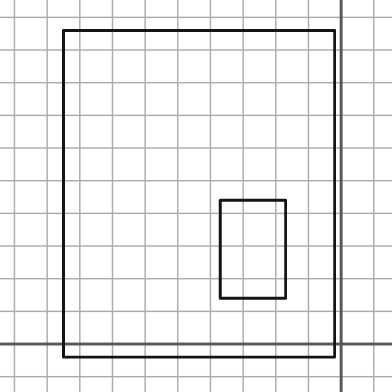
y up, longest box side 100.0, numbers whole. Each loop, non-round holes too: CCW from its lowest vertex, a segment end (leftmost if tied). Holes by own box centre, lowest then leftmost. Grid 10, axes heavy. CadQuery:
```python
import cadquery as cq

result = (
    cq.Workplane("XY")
    .moveTo(-85.0, -4.0)
    .lineTo(-2.0, -4.0)
    .lineTo(-2.0, 96.0)
    .lineTo(-85.0, 96.0)
    .close()
    .moveTo(-37.0, 14.0)
    .lineTo(-17.0, 14.0)
    .lineTo(-17.0, 44.0)
    .lineTo(-37.0, 44.0)
    .close()
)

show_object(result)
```